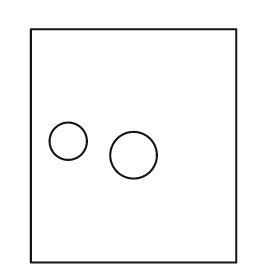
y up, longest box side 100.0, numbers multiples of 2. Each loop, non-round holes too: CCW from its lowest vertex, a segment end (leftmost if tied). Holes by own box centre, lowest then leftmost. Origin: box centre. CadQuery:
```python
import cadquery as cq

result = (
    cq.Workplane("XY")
    .moveTo(-44.0, -50.0)
    .lineTo(44.0, -50.0)
    .lineTo(44.0, 50.0)
    .lineTo(-44.0, 50.0)
    .close()
    .moveTo(0.0, -4.0)
    .circle(10.0)
    .moveTo(-28.0, 2.0)
    .circle(8.0)
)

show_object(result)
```